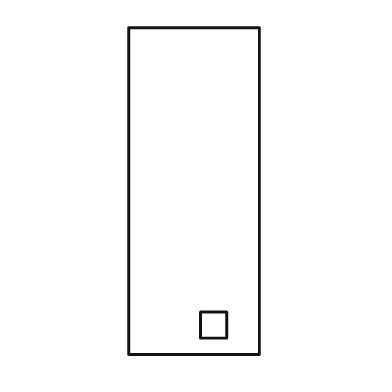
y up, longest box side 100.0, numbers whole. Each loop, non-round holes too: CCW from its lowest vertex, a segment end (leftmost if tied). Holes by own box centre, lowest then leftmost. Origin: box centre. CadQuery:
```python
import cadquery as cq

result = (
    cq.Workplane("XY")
    .moveTo(-20.0, -50.0)
    .lineTo(20.0, -50.0)
    .lineTo(20.0, 50.0)
    .lineTo(-20.0, 50.0)
    .close()
    .moveTo(2.0, -45.0)
    .lineTo(10.0, -45.0)
    .lineTo(10.0, -37.0)
    .lineTo(2.0, -37.0)
    .close()
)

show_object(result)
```